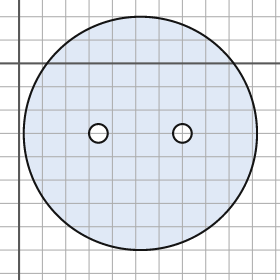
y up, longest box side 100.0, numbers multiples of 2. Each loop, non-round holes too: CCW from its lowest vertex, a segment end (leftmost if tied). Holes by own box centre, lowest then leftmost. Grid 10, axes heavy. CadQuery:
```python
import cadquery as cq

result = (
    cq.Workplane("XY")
    .moveTo(52.0, -30.0)
    .circle(50.0)
    .moveTo(34.0, -30.0)
    .circle(4.0)
    .moveTo(70.0, -30.0)
    .circle(4.0)
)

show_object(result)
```